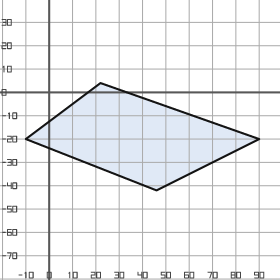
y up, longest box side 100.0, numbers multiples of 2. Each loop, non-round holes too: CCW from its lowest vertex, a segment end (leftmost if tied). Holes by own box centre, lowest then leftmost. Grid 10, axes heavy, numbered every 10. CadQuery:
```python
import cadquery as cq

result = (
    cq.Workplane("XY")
    .moveTo(46.0, -42.0)
    .lineTo(90.0, -20.0)
    .lineTo(22.0, 4.0)
    .lineTo(-10.0, -20.0)
    .close()
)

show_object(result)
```